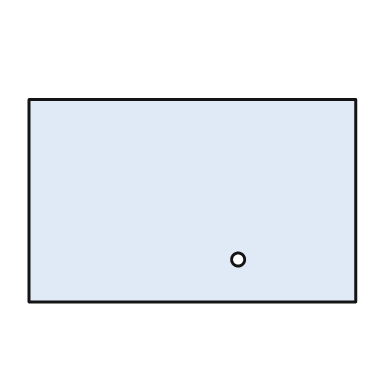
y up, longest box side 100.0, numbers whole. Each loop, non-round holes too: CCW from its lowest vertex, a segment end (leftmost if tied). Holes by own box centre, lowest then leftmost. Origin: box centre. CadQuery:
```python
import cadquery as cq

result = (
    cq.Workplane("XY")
    .moveTo(-50.0, -31.0)
    .lineTo(50.0, -31.0)
    .lineTo(50.0, 31.0)
    .lineTo(-50.0, 31.0)
    .close()
    .moveTo(14.0, -18.0)
    .circle(2.0)
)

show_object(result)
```